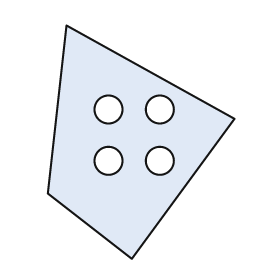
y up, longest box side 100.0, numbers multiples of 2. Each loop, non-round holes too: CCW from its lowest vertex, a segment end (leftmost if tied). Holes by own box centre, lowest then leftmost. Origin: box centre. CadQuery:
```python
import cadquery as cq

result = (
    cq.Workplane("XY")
    .moveTo(-4.0, -50.0)
    .lineTo(40.0, 10.0)
    .lineTo(-32.0, 50.0)
    .lineTo(-40.0, -22.0)
    .close()
    .moveTo(-14.0, -8.0)
    .circle(6.0)
    .moveTo(8.0, -8.0)
    .circle(6.0)
    .moveTo(-14.0, 14.0)
    .circle(6.0)
    .moveTo(8.0, 14.0)
    .circle(6.0)
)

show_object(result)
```